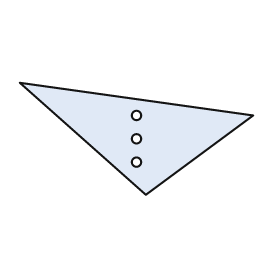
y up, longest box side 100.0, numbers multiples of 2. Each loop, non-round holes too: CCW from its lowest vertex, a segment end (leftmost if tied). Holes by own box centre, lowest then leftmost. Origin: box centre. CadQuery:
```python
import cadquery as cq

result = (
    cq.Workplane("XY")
    .moveTo(4.0, -24.0)
    .lineTo(50.0, 10.0)
    .lineTo(-50.0, 24.0)
    .close()
    .moveTo(0.0, -10.0)
    .circle(2.0)
    .moveTo(0.0, 0.0)
    .circle(2.0)
    .moveTo(0.0, 10.0)
    .circle(2.0)
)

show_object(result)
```